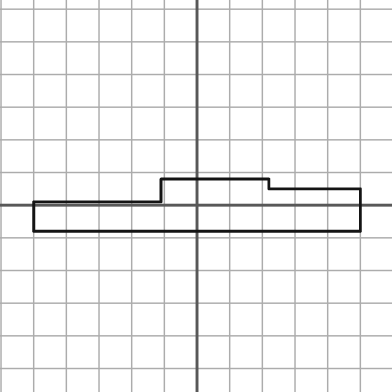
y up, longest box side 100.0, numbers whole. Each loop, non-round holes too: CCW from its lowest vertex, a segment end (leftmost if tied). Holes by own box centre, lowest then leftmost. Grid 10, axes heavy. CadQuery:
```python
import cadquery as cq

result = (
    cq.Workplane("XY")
    .moveTo(-50.0, -8.0)
    .lineTo(50.0, -8.0)
    .lineTo(50.0, 5.0)
    .lineTo(22.0, 5.0)
    .lineTo(22.0, 8.0)
    .lineTo(-11.0, 8.0)
    .lineTo(-11.0, 1.0)
    .lineTo(-50.0, 1.0)
    .close()
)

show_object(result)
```